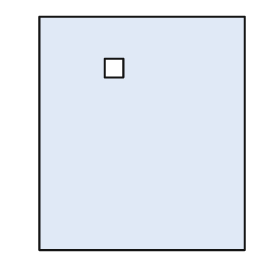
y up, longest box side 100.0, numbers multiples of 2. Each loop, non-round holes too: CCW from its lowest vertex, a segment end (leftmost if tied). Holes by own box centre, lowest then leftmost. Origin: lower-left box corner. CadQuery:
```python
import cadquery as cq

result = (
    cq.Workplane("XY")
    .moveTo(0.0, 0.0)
    .lineTo(88.0, 0.0)
    .lineTo(88.0, 100.0)
    .lineTo(0.0, 100.0)
    .close()
    .moveTo(28.0, 74.0)
    .lineTo(36.0, 74.0)
    .lineTo(36.0, 82.0)
    .lineTo(28.0, 82.0)
    .close()
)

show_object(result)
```